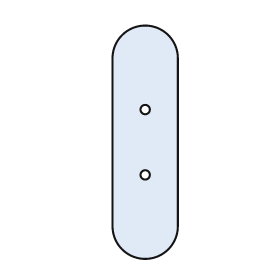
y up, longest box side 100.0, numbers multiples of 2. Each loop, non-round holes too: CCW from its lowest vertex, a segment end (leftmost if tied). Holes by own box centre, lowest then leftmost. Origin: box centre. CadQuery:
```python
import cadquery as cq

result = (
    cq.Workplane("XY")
    .moveTo(-14.0, -36.0)
    .threePointArc((0.0, -50.0), (14.0, -36.0))
    .lineTo(14.0, 36.0)
    .threePointArc((0.0, 50.0), (-14.0, 36.0))
    .close()
    .moveTo(0.0, -14.0)
    .circle(2.0)
    .moveTo(0.0, 14.0)
    .circle(2.0)
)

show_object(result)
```